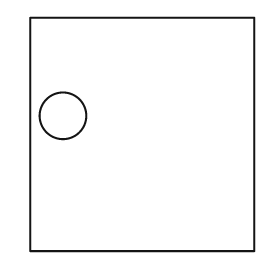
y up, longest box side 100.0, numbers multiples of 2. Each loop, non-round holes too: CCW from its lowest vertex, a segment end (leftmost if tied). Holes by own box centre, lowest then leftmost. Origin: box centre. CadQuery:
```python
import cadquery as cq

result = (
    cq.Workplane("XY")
    .moveTo(-48.0, -50.0)
    .lineTo(48.0, -50.0)
    .lineTo(48.0, 50.0)
    .lineTo(-48.0, 50.0)
    .close()
    .moveTo(-34.0, 8.0)
    .circle(10.0)
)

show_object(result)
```